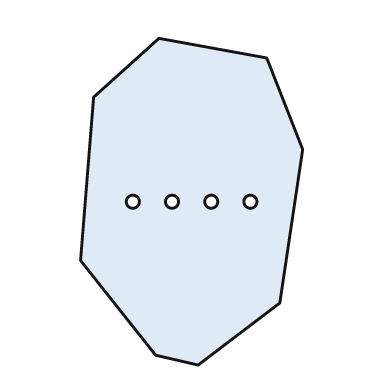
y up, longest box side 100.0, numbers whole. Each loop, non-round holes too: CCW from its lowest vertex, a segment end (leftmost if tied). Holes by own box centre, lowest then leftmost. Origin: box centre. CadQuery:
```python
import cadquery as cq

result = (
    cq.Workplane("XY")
    .moveTo(2.0, -50.0)
    .lineTo(27.0, -31.0)
    .lineTo(34.0, 16.0)
    .lineTo(23.0, 44.0)
    .lineTo(-10.0, 50.0)
    .lineTo(-30.0, 32.0)
    .lineTo(-34.0, -18.0)
    .lineTo(-11.0, -47.0)
    .close()
    .moveTo(-18.0, 0.0)
    .circle(2.0)
    .moveTo(-6.0, 0.0)
    .circle(2.0)
    .moveTo(6.0, 0.0)
    .circle(2.0)
    .moveTo(18.0, 0.0)
    .circle(2.0)
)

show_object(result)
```